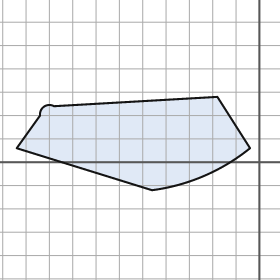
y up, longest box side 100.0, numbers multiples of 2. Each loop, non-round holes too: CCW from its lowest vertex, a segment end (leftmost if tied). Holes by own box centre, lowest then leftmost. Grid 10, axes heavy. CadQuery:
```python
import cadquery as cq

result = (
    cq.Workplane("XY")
    .moveTo(-46.0, -12.0)
    .threePointArc((-24.0, -6.0), (-4.0, 6.0))
    .lineTo(-18.0, 28.0)
    .lineTo(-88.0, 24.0)
    .threePointArc((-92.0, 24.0), (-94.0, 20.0))
    .lineTo(-104.0, 6.0)
    .close()
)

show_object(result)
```